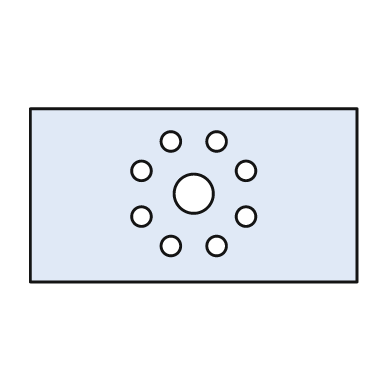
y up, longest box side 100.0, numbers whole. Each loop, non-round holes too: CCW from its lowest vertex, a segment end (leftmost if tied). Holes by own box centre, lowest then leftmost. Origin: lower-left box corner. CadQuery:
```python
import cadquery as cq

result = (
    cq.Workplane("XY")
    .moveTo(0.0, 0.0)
    .lineTo(100.0, 0.0)
    .lineTo(100.0, 53.0)
    .lineTo(0.0, 53.0)
    .close()
    .moveTo(43.0, 11.0)
    .circle(3.0)
    .moveTo(57.0, 11.0)
    .circle(3.0)
    .moveTo(34.0, 20.0)
    .circle(3.0)
    .moveTo(66.0, 20.0)
    .circle(3.0)
    .moveTo(50.0, 27.0)
    .circle(6.0)
    .moveTo(34.0, 34.0)
    .circle(3.0)
    .moveTo(66.0, 34.0)
    .circle(3.0)
    .moveTo(43.0, 43.0)
    .circle(3.0)
    .moveTo(57.0, 43.0)
    .circle(3.0)
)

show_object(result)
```